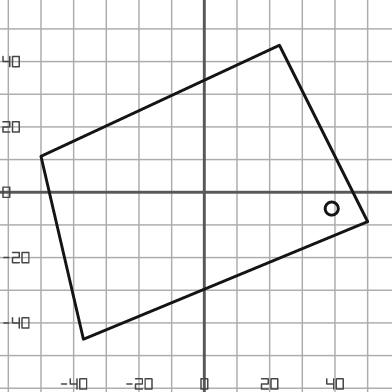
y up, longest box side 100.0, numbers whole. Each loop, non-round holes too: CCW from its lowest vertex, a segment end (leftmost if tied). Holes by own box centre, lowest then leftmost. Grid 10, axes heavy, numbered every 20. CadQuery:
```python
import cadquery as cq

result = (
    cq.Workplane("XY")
    .moveTo(-37.0, -45.0)
    .lineTo(50.0, -9.0)
    .lineTo(23.0, 45.0)
    .lineTo(-50.0, 11.0)
    .close()
    .moveTo(39.0, -5.0)
    .circle(2.0)
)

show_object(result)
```